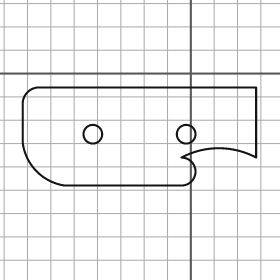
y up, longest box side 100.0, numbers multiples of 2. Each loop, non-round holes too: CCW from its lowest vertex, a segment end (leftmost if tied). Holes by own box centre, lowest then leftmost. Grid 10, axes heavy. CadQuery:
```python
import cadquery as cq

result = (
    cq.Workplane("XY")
    .moveTo(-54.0, -48.0)
    .lineTo(-4.0, -48.0)
    .threePointArc((2.0, -42.0), (-4.0, -36.0))
    .threePointArc((12.0, -32.0), (28.0, -36.0))
    .lineTo(28.0, -6.0)
    .lineTo(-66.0, -6.0)
    .threePointArc((-70.0, -8.0), (-72.0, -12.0))
    .lineTo(-72.0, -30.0)
    .threePointArc((-66.0, -42.0), (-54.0, -48.0))
    .close()
    .moveTo(-42.0, -26.0)
    .circle(4.0)
    .moveTo(-2.0, -26.0)
    .circle(4.0)
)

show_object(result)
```